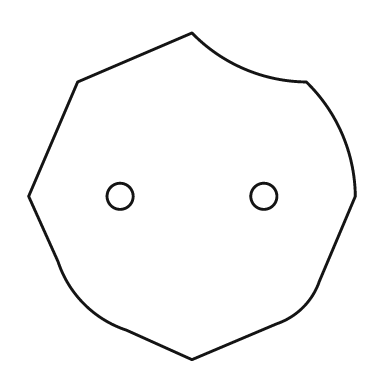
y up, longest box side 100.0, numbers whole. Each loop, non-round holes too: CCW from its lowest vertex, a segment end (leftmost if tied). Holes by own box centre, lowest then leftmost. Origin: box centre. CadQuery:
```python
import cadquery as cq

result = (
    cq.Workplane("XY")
    .moveTo(0.0, -50.0)
    .lineTo(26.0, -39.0)
    .threePointArc((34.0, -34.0), (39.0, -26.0))
    .lineTo(50.0, 0.0)
    .threePointArc((46.0, 19.0), (35.0, 35.0))
    .threePointArc((16.0, 39.0), (0.0, 50.0))
    .lineTo(-35.0, 35.0)
    .lineTo(-50.0, 0.0)
    .lineTo(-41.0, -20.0)
    .threePointArc((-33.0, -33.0), (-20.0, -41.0))
    .close()
    .moveTo(-22.0, 0.0)
    .circle(4.0)
    .moveTo(22.0, 0.0)
    .circle(4.0)
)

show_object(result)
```